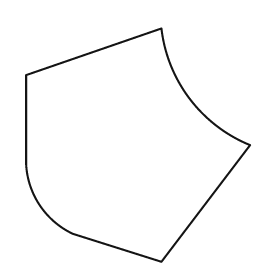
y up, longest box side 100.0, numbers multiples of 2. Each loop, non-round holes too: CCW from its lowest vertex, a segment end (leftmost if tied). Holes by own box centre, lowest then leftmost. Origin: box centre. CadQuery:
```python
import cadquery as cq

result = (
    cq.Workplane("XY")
    .moveTo(10.0, -50.0)
    .lineTo(48.0, 0.0)
    .threePointArc((22.0, 20.0), (10.0, 50.0))
    .lineTo(-48.0, 30.0)
    .lineTo(-48.0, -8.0)
    .threePointArc((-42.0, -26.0), (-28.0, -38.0))
    .close()
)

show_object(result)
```